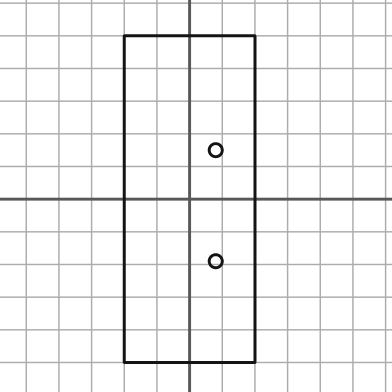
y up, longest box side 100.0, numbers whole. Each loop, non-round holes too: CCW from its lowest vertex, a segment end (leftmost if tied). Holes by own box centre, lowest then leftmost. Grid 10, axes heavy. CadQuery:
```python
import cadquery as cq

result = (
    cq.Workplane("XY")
    .moveTo(-20.0, -50.0)
    .lineTo(20.0, -50.0)
    .lineTo(20.0, 50.0)
    .lineTo(-20.0, 50.0)
    .close()
    .moveTo(8.0, -19.0)
    .circle(2.0)
    .moveTo(8.0, 15.0)
    .circle(2.0)
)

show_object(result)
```